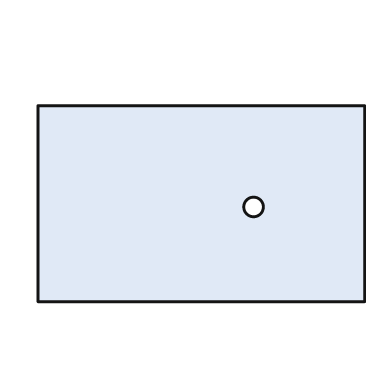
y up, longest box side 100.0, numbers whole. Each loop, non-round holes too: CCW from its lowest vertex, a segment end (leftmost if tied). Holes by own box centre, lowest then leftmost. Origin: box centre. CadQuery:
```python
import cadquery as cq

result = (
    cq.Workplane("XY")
    .moveTo(-50.0, -30.0)
    .lineTo(50.0, -30.0)
    .lineTo(50.0, 30.0)
    .lineTo(-50.0, 30.0)
    .close()
    .moveTo(16.0, -1.0)
    .circle(3.0)
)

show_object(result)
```